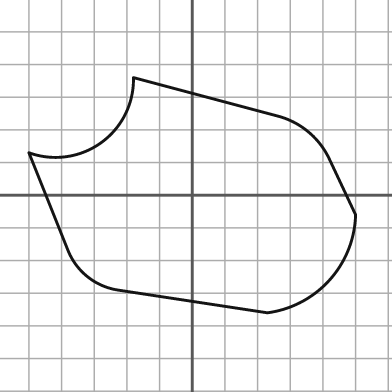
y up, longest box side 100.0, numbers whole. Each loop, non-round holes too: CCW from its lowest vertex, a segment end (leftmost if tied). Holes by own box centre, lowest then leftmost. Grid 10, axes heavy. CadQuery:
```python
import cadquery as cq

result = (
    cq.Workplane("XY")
    .moveTo(23.0, -36.0)
    .threePointArc((42.0, -26.0), (50.0, -6.0))
    .lineTo(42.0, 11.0)
    .threePointArc((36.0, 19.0), (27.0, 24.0))
    .lineTo(-18.0, 36.0)
    .threePointArc((-28.0, 16.0), (-50.0, 13.0))
    .lineTo(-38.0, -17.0)
    .threePointArc((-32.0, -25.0), (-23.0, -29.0))
    .close()
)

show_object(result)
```